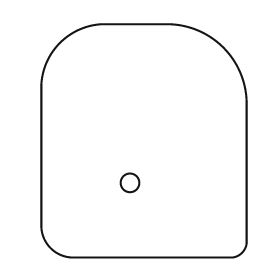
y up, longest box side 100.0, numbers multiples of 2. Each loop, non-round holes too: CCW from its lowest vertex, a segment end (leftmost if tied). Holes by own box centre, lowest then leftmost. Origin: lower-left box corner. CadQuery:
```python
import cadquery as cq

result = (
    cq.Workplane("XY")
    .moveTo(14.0, 0.0)
    .lineTo(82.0, 0.0)
    .threePointArc((86.0, 2.0), (88.0, 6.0))
    .lineTo(88.0, 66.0)
    .threePointArc((78.0, 90.0), (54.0, 100.0))
    .lineTo(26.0, 100.0)
    .threePointArc((8.0, 92.0), (0.0, 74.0))
    .lineTo(0.0, 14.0)
    .threePointArc((4.0, 4.0), (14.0, 0.0))
    .close()
    .moveTo(38.0, 32.0)
    .circle(4.0)
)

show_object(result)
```